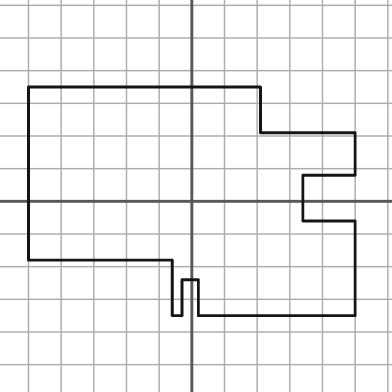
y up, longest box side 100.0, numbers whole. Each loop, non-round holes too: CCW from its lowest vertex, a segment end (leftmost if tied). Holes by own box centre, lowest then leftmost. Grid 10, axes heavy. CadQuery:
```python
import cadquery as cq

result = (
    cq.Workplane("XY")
    .moveTo(-6.0, -35.0)
    .lineTo(-3.0, -35.0)
    .lineTo(-3.0, -24.0)
    .lineTo(2.0, -24.0)
    .lineTo(2.0, -35.0)
    .lineTo(50.0, -35.0)
    .lineTo(50.0, -6.0)
    .lineTo(34.0, -6.0)
    .lineTo(34.0, 8.0)
    .lineTo(50.0, 8.0)
    .lineTo(50.0, 21.0)
    .lineTo(21.0, 21.0)
    .lineTo(21.0, 35.0)
    .lineTo(-50.0, 35.0)
    .lineTo(-50.0, -18.0)
    .lineTo(-6.0, -18.0)
    .close()
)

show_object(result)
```